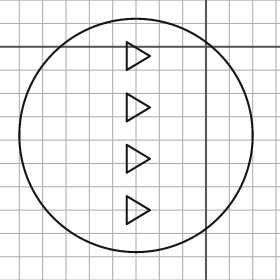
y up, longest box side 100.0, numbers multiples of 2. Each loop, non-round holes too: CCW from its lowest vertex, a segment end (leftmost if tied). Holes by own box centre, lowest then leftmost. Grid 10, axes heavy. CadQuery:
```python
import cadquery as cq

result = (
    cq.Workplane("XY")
    .moveTo(-30.0, -38.0)
    .circle(50.0)
    .moveTo(-34.0, -76.0)
    .lineTo(-24.0, -70.0)
    .lineTo(-34.0, -64.0)
    .close()
    .moveTo(-34.0, -54.0)
    .lineTo(-24.0, -48.0)
    .lineTo(-34.0, -42.0)
    .close()
    .moveTo(-34.0, -32.0)
    .lineTo(-24.0, -26.0)
    .lineTo(-34.0, -20.0)
    .close()
    .moveTo(-34.0, -10.0)
    .lineTo(-24.0, -4.0)
    .lineTo(-34.0, 2.0)
    .close()
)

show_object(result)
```